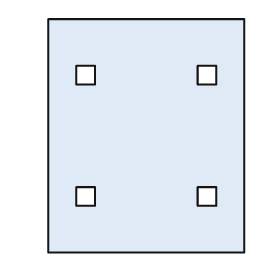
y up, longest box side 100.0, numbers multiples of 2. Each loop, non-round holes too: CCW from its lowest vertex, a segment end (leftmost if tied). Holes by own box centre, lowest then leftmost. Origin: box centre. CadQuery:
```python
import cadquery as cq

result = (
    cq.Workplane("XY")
    .moveTo(-42.0, -50.0)
    .lineTo(42.0, -50.0)
    .lineTo(42.0, 50.0)
    .lineTo(-42.0, 50.0)
    .close()
    .moveTo(-30.0, -30.0)
    .lineTo(-22.0, -30.0)
    .lineTo(-22.0, -22.0)
    .lineTo(-30.0, -22.0)
    .close()
    .moveTo(22.0, -30.0)
    .lineTo(30.0, -30.0)
    .lineTo(30.0, -22.0)
    .lineTo(22.0, -22.0)
    .close()
    .moveTo(-30.0, 22.0)
    .lineTo(-22.0, 22.0)
    .lineTo(-22.0, 30.0)
    .lineTo(-30.0, 30.0)
    .close()
    .moveTo(22.0, 22.0)
    .lineTo(30.0, 22.0)
    .lineTo(30.0, 30.0)
    .lineTo(22.0, 30.0)
    .close()
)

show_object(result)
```